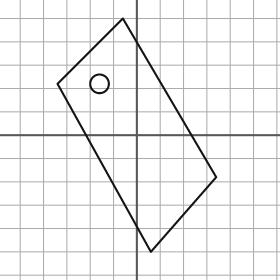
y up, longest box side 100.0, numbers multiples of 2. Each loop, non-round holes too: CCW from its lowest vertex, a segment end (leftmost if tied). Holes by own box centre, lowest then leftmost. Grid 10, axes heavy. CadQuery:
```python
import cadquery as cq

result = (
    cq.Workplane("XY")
    .moveTo(6.0, -50.0)
    .lineTo(34.0, -18.0)
    .lineTo(-6.0, 50.0)
    .lineTo(-34.0, 22.0)
    .close()
    .moveTo(-16.0, 22.0)
    .circle(4.0)
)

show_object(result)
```